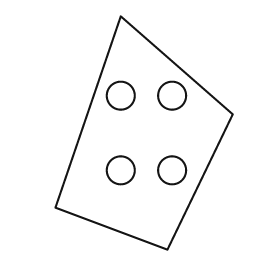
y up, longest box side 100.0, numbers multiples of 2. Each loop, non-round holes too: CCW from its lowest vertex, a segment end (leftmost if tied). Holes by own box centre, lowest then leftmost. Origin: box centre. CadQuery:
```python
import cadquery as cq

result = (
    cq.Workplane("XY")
    .moveTo(10.0, -50.0)
    .lineTo(38.0, 8.0)
    .lineTo(-10.0, 50.0)
    .lineTo(-38.0, -32.0)
    .close()
    .moveTo(-10.0, -16.0)
    .circle(6.0)
    .moveTo(12.0, -16.0)
    .circle(6.0)
    .moveTo(-10.0, 16.0)
    .circle(6.0)
    .moveTo(12.0, 16.0)
    .circle(6.0)
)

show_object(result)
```